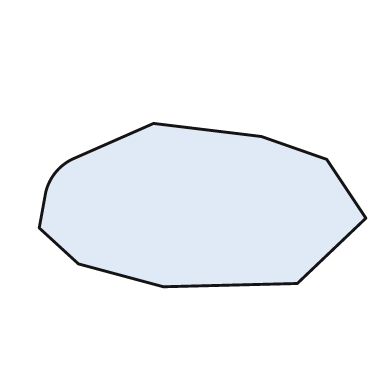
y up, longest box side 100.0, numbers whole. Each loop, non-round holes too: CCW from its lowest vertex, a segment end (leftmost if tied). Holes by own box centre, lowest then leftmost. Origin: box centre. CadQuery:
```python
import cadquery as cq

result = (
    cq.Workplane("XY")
    .moveTo(-12.0, -25.0)
    .lineTo(29.0, -24.0)
    .lineTo(50.0, -4.0)
    .lineTo(38.0, 14.0)
    .lineTo(18.0, 21.0)
    .lineTo(-15.0, 25.0)
    .lineTo(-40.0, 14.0)
    .threePointArc((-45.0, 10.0), (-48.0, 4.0))
    .lineTo(-50.0, -7.0)
    .lineTo(-38.0, -18.0)
    .close()
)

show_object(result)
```